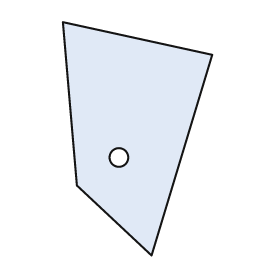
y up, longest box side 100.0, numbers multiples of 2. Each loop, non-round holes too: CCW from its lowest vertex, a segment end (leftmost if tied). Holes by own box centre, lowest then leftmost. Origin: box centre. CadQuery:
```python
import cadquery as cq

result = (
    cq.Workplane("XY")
    .moveTo(6.0, -50.0)
    .lineTo(32.0, 36.0)
    .lineTo(-32.0, 50.0)
    .lineTo(-26.0, -20.0)
    .close()
    .moveTo(-8.0, -8.0)
    .circle(4.0)
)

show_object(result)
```